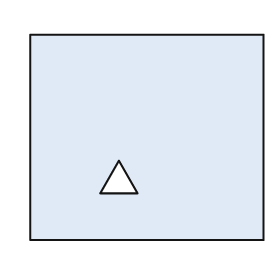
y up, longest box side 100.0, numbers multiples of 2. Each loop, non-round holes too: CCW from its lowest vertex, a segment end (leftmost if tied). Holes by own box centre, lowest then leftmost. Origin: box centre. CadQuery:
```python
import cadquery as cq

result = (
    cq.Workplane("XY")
    .moveTo(-50.0, -44.0)
    .lineTo(50.0, -44.0)
    .lineTo(50.0, 44.0)
    .lineTo(-50.0, 44.0)
    .close()
    .moveTo(-20.0, -24.0)
    .lineTo(-4.0, -24.0)
    .lineTo(-12.0, -10.0)
    .close()
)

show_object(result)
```